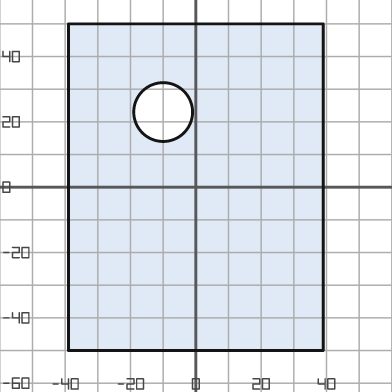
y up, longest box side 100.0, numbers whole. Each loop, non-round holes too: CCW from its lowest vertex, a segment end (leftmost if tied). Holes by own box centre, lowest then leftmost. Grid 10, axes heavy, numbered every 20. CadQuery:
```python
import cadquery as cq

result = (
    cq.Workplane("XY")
    .moveTo(-39.0, -50.0)
    .lineTo(39.0, -50.0)
    .lineTo(39.0, 50.0)
    .lineTo(-39.0, 50.0)
    .close()
    .moveTo(-10.0, 23.0)
    .circle(9.0)
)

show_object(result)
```